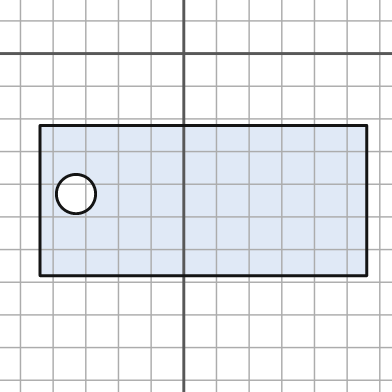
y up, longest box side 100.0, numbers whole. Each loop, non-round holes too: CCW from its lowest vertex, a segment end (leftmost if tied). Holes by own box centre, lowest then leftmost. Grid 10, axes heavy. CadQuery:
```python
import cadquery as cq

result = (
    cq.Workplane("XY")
    .moveTo(-44.0, -68.0)
    .lineTo(56.0, -68.0)
    .lineTo(56.0, -22.0)
    .lineTo(-44.0, -22.0)
    .close()
    .moveTo(-33.0, -43.0)
    .circle(6.0)
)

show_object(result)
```